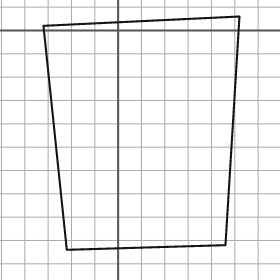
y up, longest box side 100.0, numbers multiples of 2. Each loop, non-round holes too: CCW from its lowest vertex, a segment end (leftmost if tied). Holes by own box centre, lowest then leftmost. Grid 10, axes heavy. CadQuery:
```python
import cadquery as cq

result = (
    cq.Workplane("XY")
    .moveTo(-22.0, -94.0)
    .lineTo(46.0, -92.0)
    .lineTo(52.0, 6.0)
    .lineTo(-32.0, 2.0)
    .close()
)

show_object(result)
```